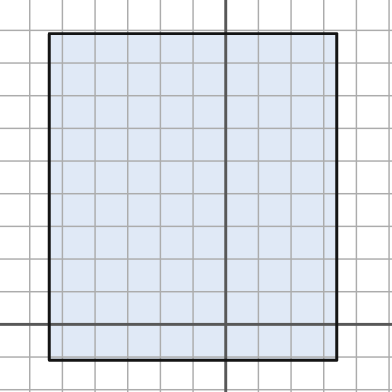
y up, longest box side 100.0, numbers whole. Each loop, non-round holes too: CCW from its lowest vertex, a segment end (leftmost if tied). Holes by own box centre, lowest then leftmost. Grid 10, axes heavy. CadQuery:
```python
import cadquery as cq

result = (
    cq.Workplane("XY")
    .moveTo(-54.0, -11.0)
    .lineTo(34.0, -11.0)
    .lineTo(34.0, 89.0)
    .lineTo(-54.0, 89.0)
    .close()
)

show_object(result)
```